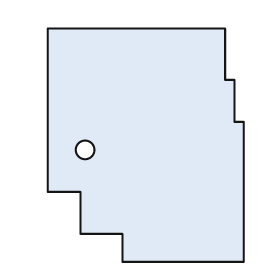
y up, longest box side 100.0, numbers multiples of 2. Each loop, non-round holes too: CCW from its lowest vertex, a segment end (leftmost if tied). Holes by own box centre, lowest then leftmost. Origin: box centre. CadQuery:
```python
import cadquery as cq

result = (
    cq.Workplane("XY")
    .moveTo(-10.0, -50.0)
    .lineTo(42.0, -50.0)
    .lineTo(42.0, 10.0)
    .lineTo(38.0, 10.0)
    .lineTo(38.0, 28.0)
    .lineTo(34.0, 28.0)
    .lineTo(34.0, 50.0)
    .lineTo(-42.0, 50.0)
    .lineTo(-42.0, -20.0)
    .lineTo(-28.0, -20.0)
    .lineTo(-28.0, -38.0)
    .lineTo(-10.0, -38.0)
    .close()
    .moveTo(-26.0, -2.0)
    .circle(4.0)
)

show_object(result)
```